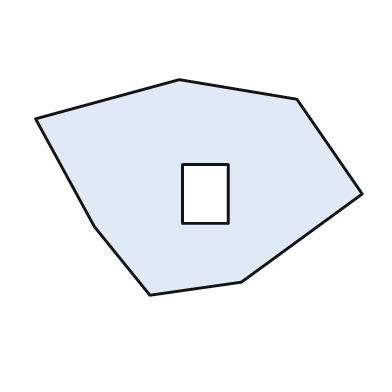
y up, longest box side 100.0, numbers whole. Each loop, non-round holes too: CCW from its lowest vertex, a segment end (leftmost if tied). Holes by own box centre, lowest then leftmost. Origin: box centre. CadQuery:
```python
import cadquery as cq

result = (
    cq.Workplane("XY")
    .moveTo(-15.0, -33.0)
    .lineTo(13.0, -29.0)
    .lineTo(50.0, -2.0)
    .lineTo(30.0, 27.0)
    .lineTo(-6.0, 33.0)
    .lineTo(-50.0, 21.0)
    .lineTo(-32.0, -12.0)
    .close()
    .moveTo(-5.0, -11.0)
    .lineTo(9.0, -11.0)
    .lineTo(9.0, 7.0)
    .lineTo(-5.0, 7.0)
    .close()
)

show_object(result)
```